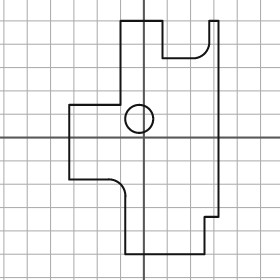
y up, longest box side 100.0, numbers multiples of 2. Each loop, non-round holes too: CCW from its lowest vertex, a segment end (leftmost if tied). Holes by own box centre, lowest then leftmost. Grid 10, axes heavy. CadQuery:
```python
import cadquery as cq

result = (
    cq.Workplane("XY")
    .moveTo(-8.0, -50.0)
    .lineTo(26.0, -50.0)
    .lineTo(26.0, -34.0)
    .lineTo(32.0, -34.0)
    .lineTo(32.0, 50.0)
    .lineTo(28.0, 50.0)
    .lineTo(28.0, 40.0)
    .threePointArc((26.0, 36.0), (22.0, 34.0))
    .lineTo(8.0, 34.0)
    .lineTo(8.0, 50.0)
    .lineTo(-10.0, 50.0)
    .lineTo(-10.0, 14.0)
    .lineTo(-32.0, 14.0)
    .lineTo(-32.0, -18.0)
    .lineTo(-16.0, -18.0)
    .threePointArc((-10.0, -20.0), (-8.0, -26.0))
    .close()
    .moveTo(-2.0, 8.0)
    .circle(6.0)
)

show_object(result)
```